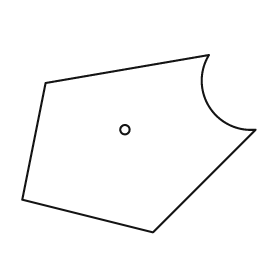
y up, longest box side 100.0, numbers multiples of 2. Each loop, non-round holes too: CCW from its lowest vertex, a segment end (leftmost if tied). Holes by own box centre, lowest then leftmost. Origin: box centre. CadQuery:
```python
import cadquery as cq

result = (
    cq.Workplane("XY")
    .moveTo(6.0, -38.0)
    .lineTo(50.0, 6.0)
    .threePointArc((30.0, 16.0), (30.0, 38.0))
    .lineTo(-40.0, 26.0)
    .lineTo(-50.0, -24.0)
    .close()
    .moveTo(-6.0, 6.0)
    .circle(2.0)
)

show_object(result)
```